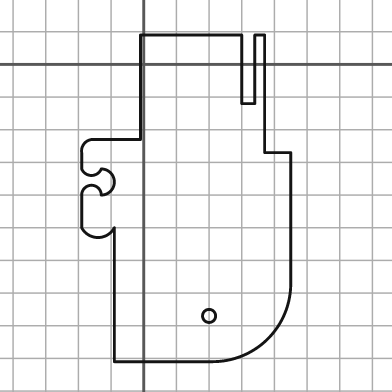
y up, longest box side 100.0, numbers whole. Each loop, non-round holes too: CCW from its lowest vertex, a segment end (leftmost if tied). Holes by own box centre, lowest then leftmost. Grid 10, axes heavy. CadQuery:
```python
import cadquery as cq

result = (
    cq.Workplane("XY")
    .moveTo(-9.0, -91.0)
    .lineTo(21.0, -91.0)
    .threePointArc((38.0, -84.0), (45.0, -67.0))
    .lineTo(45.0, -27.0)
    .lineTo(37.0, -27.0)
    .lineTo(37.0, 9.0)
    .lineTo(34.0, 9.0)
    .lineTo(34.0, -12.0)
    .lineTo(30.0, -12.0)
    .lineTo(30.0, 9.0)
    .lineTo(-1.0, 9.0)
    .lineTo(-1.0, -23.0)
    .lineTo(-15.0, -23.0)
    .threePointArc((-18.0, -24.0), (-19.0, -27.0))
    .lineTo(-19.0, -32.0)
    .threePointArc((-16.0, -34.0), (-13.0, -32.0))
    .threePointArc((-9.0, -36.0), (-13.0, -40.0))
    .threePointArc((-16.0, -37.0), (-19.0, -40.0))
    .lineTo(-19.0, -50.0)
    .threePointArc((-14.0, -53.0), (-9.0, -50.0))
    .close()
    .moveTo(20.0, -77.0)
    .circle(2.0)
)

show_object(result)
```